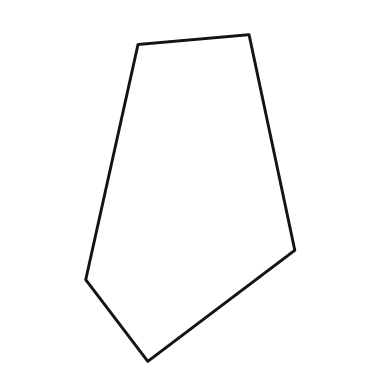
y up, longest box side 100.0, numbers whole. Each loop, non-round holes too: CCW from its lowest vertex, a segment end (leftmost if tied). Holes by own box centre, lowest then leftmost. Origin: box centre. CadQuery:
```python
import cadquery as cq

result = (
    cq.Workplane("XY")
    .moveTo(-13.0, -50.0)
    .lineTo(32.0, -16.0)
    .lineTo(18.0, 50.0)
    .lineTo(-16.0, 47.0)
    .lineTo(-32.0, -25.0)
    .close()
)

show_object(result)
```